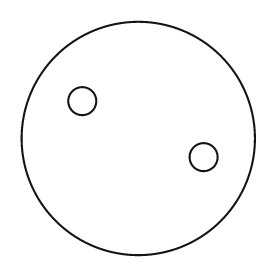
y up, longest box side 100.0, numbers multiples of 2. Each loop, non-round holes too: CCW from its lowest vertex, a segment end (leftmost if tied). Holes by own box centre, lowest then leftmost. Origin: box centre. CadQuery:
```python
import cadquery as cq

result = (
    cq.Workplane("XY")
    .moveTo(0.0, 0.0)
    .circle(50.0)
    .moveTo(28.0, -8.0)
    .circle(6.0)
    .moveTo(-24.0, 16.0)
    .circle(6.0)
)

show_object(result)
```